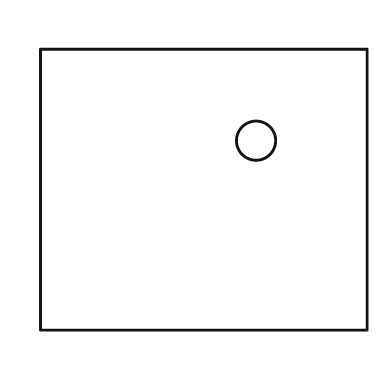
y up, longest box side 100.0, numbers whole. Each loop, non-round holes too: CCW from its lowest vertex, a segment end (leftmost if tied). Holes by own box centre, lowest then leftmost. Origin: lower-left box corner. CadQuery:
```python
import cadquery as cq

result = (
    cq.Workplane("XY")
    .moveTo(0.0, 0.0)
    .lineTo(100.0, 0.0)
    .lineTo(100.0, 86.0)
    .lineTo(0.0, 86.0)
    .close()
    .moveTo(66.0, 58.0)
    .circle(6.0)
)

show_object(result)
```